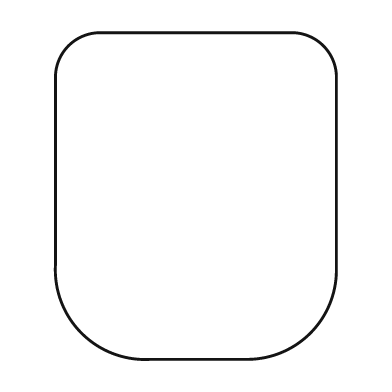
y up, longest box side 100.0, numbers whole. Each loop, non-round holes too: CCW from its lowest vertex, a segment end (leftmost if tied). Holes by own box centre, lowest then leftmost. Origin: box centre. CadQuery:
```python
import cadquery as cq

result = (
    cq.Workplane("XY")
    .moveTo(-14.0, -50.0)
    .lineTo(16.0, -50.0)
    .threePointArc((35.0, -42.0), (43.0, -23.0))
    .lineTo(43.0, 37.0)
    .threePointArc((39.0, 46.0), (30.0, 50.0))
    .lineTo(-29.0, 50.0)
    .threePointArc((-39.0, 46.0), (-43.0, 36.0))
    .lineTo(-43.0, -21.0)
    .threePointArc((-35.0, -42.0), (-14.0, -50.0))
    .close()
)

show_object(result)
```